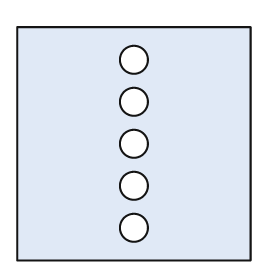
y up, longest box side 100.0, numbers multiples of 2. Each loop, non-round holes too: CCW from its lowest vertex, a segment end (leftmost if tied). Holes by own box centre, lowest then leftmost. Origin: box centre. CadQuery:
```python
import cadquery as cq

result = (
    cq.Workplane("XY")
    .moveTo(-50.0, -50.0)
    .lineTo(50.0, -50.0)
    .lineTo(50.0, 50.0)
    .lineTo(-50.0, 50.0)
    .close()
    .moveTo(0.0, -36.0)
    .circle(6.0)
    .moveTo(0.0, -18.0)
    .circle(6.0)
    .moveTo(0.0, 0.0)
    .circle(6.0)
    .moveTo(0.0, 18.0)
    .circle(6.0)
    .moveTo(0.0, 36.0)
    .circle(6.0)
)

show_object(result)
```